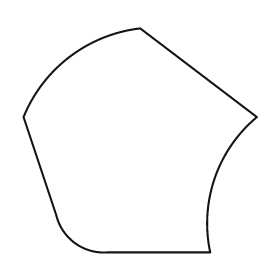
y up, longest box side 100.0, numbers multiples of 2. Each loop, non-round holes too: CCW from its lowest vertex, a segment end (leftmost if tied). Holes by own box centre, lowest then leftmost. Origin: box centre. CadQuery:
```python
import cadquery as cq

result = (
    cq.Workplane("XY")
    .moveTo(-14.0, -48.0)
    .lineTo(30.0, -48.0)
    .threePointArc((32.0, -16.0), (50.0, 10.0))
    .lineTo(0.0, 48.0)
    .threePointArc((-30.0, 36.0), (-50.0, 10.0))
    .lineTo(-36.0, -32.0)
    .threePointArc((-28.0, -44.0), (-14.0, -48.0))
    .close()
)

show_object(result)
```